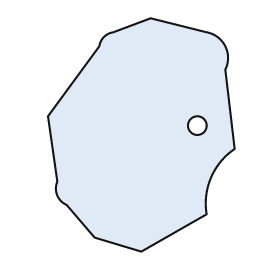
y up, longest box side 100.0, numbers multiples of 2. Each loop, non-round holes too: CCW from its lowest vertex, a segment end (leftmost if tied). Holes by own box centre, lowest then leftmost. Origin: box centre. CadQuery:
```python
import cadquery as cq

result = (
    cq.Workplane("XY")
    .moveTo(0.0, -50.0)
    .lineTo(28.0, -34.0)
    .threePointArc((30.0, -18.0), (40.0, -6.0))
    .lineTo(36.0, 28.0)
    .threePointArc((36.0, 38.0), (28.0, 44.0))
    .lineTo(4.0, 50.0)
    .lineTo(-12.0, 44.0)
    .threePointArc((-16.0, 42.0), (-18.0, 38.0))
    .lineTo(-40.0, 8.0)
    .lineTo(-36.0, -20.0)
    .threePointArc((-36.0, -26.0), (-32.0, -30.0))
    .lineTo(-20.0, -44.0)
    .close()
    .moveTo(24.0, 4.0)
    .circle(4.0)
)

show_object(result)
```